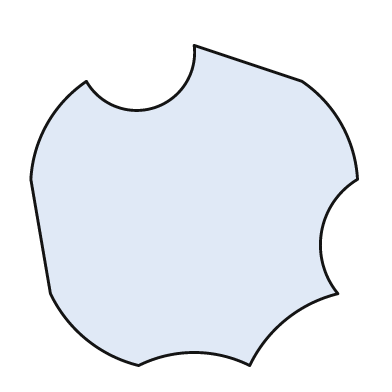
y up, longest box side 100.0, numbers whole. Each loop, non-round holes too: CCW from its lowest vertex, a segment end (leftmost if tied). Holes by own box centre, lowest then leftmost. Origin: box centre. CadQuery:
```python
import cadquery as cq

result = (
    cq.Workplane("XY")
    .moveTo(-17.0, -49.0)
    .threePointArc((0.0, -45.0), (17.0, -49.0))
    .threePointArc((28.0, -35.0), (44.0, -27.0))
    .threePointArc((39.0, -8.0), (50.0, 8.0))
    .threePointArc((45.0, 25.0), (33.0, 38.0))
    .lineTo(0.0, 49.0)
    .threePointArc((-12.0, 30.0), (-33.0, 38.0))
    .threePointArc((-45.0, 25.0), (-50.0, 8.0))
    .lineTo(-44.0, -27.0)
    .threePointArc((-33.0, -41.0), (-17.0, -49.0))
    .close()
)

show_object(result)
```